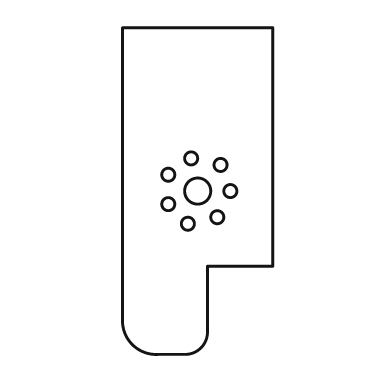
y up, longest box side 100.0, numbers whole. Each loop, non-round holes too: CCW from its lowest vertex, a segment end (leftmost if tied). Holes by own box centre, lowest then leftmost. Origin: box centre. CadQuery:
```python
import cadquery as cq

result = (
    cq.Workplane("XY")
    .moveTo(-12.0, -50.0)
    .lineTo(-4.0, -50.0)
    .threePointArc((1.0, -48.0), (3.0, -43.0))
    .lineTo(3.0, -23.0)
    .lineTo(23.0, -23.0)
    .lineTo(23.0, 50.0)
    .lineTo(-23.0, 50.0)
    .lineTo(-23.0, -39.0)
    .threePointArc((-20.0, -47.0), (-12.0, -50.0))
    .close()
    .moveTo(-3.0, -10.0)
    .circle(2.0)
    .moveTo(6.0, -8.0)
    .circle(2.0)
    .moveTo(-9.0, -4.0)
    .circle(2.0)
    .moveTo(0.0, 0.0)
    .circle(4.0)
    .moveTo(10.0, 0.0)
    .circle(2.0)
    .moveTo(-9.0, 5.0)
    .circle(2.0)
    .moveTo(7.0, 8.0)
    .circle(2.0)
    .moveTo(-2.0, 10.0)
    .circle(2.0)
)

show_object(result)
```